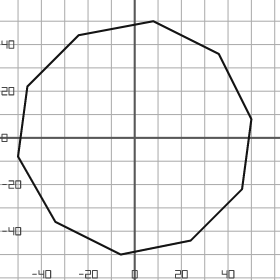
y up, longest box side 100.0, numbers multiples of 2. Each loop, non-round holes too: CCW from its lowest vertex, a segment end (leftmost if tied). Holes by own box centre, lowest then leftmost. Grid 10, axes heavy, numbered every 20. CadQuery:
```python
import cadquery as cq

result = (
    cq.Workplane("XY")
    .moveTo(-6.0, -50.0)
    .lineTo(24.0, -44.0)
    .lineTo(46.0, -22.0)
    .lineTo(50.0, 8.0)
    .lineTo(36.0, 36.0)
    .lineTo(8.0, 50.0)
    .lineTo(-24.0, 44.0)
    .lineTo(-46.0, 22.0)
    .lineTo(-50.0, -8.0)
    .lineTo(-34.0, -36.0)
    .close()
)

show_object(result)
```